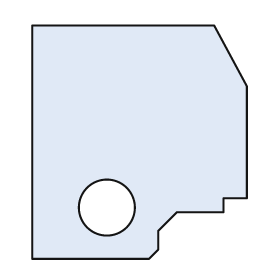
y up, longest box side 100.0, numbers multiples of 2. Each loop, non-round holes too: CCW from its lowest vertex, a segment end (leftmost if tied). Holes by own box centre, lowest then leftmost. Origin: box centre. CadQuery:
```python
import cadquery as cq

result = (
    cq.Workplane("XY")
    .moveTo(-46.0, -50.0)
    .lineTo(4.0, -50.0)
    .lineTo(8.0, -46.0)
    .lineTo(8.0, -38.0)
    .lineTo(16.0, -30.0)
    .lineTo(36.0, -30.0)
    .lineTo(36.0, -24.0)
    .lineTo(46.0, -24.0)
    .lineTo(46.0, 24.0)
    .lineTo(32.0, 50.0)
    .lineTo(-46.0, 50.0)
    .close()
    .moveTo(-14.0, -28.0)
    .circle(12.0)
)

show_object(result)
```